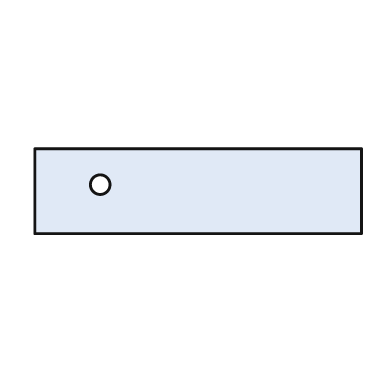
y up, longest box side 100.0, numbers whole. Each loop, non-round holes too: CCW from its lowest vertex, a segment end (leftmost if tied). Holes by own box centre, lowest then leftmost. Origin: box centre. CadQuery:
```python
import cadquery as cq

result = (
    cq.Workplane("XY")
    .moveTo(-50.0, -13.0)
    .lineTo(50.0, -13.0)
    .lineTo(50.0, 13.0)
    .lineTo(-50.0, 13.0)
    .close()
    .moveTo(-30.0, 2.0)
    .circle(3.0)
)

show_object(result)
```